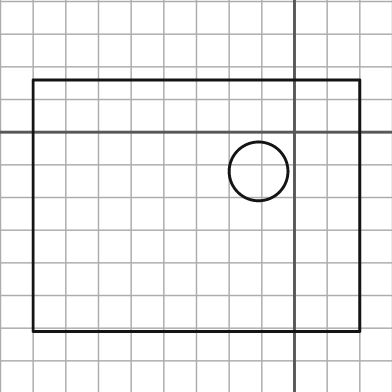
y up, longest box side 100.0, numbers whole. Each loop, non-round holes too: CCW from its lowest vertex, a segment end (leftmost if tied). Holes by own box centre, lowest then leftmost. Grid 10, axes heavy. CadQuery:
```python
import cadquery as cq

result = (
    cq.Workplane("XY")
    .moveTo(-80.0, -61.0)
    .lineTo(20.0, -61.0)
    .lineTo(20.0, 16.0)
    .lineTo(-80.0, 16.0)
    .close()
    .moveTo(-11.0, -12.0)
    .circle(9.0)
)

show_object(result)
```